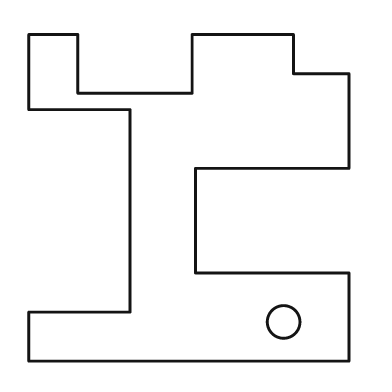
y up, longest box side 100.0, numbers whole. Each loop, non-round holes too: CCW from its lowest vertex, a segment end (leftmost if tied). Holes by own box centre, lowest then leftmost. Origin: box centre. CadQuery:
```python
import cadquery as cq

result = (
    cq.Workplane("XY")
    .moveTo(-49.0, -50.0)
    .lineTo(49.0, -50.0)
    .lineTo(49.0, -23.0)
    .lineTo(2.0, -23.0)
    .lineTo(2.0, 9.0)
    .lineTo(49.0, 9.0)
    .lineTo(49.0, 38.0)
    .lineTo(32.0, 38.0)
    .lineTo(32.0, 50.0)
    .lineTo(1.0, 50.0)
    .lineTo(1.0, 32.0)
    .lineTo(-34.0, 32.0)
    .lineTo(-34.0, 50.0)
    .lineTo(-49.0, 50.0)
    .lineTo(-49.0, 27.0)
    .lineTo(-18.0, 27.0)
    .lineTo(-18.0, -35.0)
    .lineTo(-49.0, -35.0)
    .close()
    .moveTo(29.0, -38.0)
    .circle(5.0)
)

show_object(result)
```